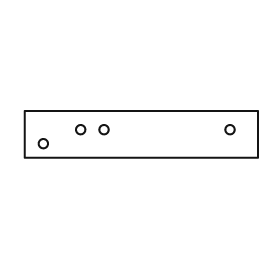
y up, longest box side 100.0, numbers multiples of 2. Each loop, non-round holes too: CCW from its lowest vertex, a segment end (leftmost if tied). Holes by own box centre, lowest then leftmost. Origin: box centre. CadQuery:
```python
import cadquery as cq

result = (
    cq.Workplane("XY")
    .moveTo(-50.0, -10.0)
    .lineTo(50.0, -10.0)
    .lineTo(50.0, 10.0)
    .lineTo(-50.0, 10.0)
    .close()
    .moveTo(-42.0, -4.0)
    .circle(2.0)
    .moveTo(-26.0, 2.0)
    .circle(2.0)
    .moveTo(-16.0, 2.0)
    .circle(2.0)
    .moveTo(38.0, 2.0)
    .circle(2.0)
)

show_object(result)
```